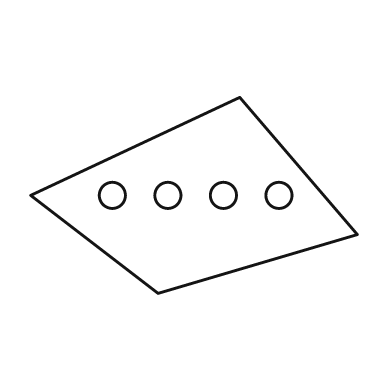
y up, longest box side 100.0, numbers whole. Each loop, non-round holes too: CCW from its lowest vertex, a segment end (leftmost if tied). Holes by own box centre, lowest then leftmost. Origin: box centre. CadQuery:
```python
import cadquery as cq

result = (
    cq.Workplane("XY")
    .moveTo(-11.0, -30.0)
    .lineTo(50.0, -12.0)
    .lineTo(14.0, 30.0)
    .lineTo(-50.0, 0.0)
    .close()
    .moveTo(-25.0, 0.0)
    .circle(4.0)
    .moveTo(-8.0, 0.0)
    .circle(4.0)
    .moveTo(9.0, 0.0)
    .circle(4.0)
    .moveTo(26.0, 0.0)
    .circle(4.0)
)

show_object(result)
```